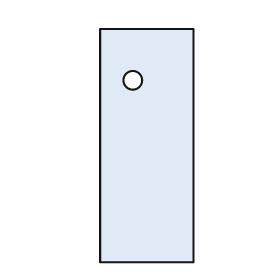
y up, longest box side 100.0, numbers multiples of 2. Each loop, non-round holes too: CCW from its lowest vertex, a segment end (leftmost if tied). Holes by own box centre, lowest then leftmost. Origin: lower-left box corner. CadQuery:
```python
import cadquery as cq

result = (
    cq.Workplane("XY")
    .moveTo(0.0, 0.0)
    .lineTo(40.0, 0.0)
    .lineTo(40.0, 100.0)
    .lineTo(0.0, 100.0)
    .close()
    .moveTo(14.0, 78.0)
    .circle(4.0)
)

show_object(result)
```